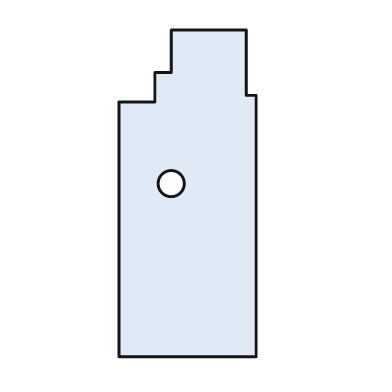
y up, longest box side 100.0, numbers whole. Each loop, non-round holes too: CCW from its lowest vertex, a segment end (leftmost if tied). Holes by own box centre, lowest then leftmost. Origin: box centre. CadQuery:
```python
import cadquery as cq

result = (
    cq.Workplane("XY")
    .moveTo(-21.0, -50.0)
    .lineTo(21.0, -50.0)
    .lineTo(21.0, 30.0)
    .lineTo(18.0, 30.0)
    .lineTo(18.0, 50.0)
    .lineTo(-5.0, 50.0)
    .lineTo(-5.0, 37.0)
    .lineTo(-10.0, 37.0)
    .lineTo(-10.0, 28.0)
    .lineTo(-21.0, 28.0)
    .close()
    .moveTo(-5.0, 3.0)
    .circle(4.0)
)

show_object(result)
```